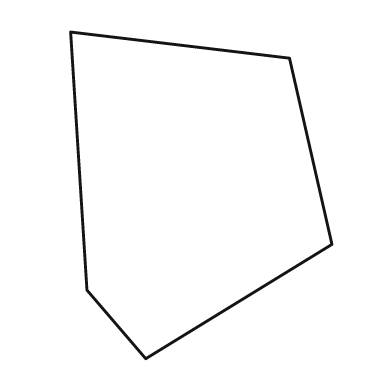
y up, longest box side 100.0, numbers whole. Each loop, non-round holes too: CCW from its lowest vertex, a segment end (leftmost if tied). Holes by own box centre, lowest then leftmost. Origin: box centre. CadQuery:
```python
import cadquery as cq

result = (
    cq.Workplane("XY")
    .moveTo(-17.0, -50.0)
    .lineTo(40.0, -15.0)
    .lineTo(27.0, 42.0)
    .lineTo(-40.0, 50.0)
    .lineTo(-35.0, -29.0)
    .close()
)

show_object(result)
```